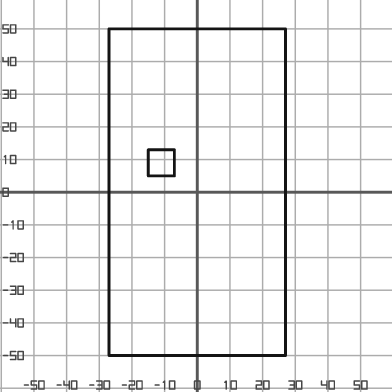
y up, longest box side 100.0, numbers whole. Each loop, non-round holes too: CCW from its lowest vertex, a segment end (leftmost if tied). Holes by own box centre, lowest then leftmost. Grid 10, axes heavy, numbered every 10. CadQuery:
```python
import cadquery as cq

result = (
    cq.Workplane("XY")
    .moveTo(-27.0, -50.0)
    .lineTo(27.0, -50.0)
    .lineTo(27.0, 50.0)
    .lineTo(-27.0, 50.0)
    .close()
    .moveTo(-15.0, 5.0)
    .lineTo(-7.0, 5.0)
    .lineTo(-7.0, 13.0)
    .lineTo(-15.0, 13.0)
    .close()
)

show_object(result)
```